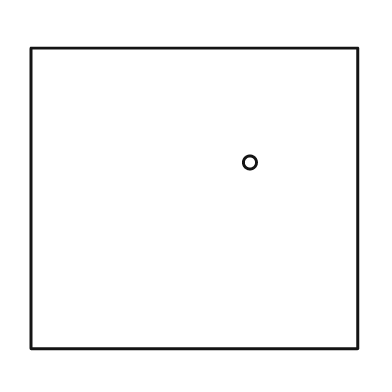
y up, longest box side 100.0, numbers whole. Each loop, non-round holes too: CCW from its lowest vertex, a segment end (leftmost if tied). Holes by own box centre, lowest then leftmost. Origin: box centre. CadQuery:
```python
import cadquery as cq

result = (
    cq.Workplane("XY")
    .moveTo(-50.0, -46.0)
    .lineTo(50.0, -46.0)
    .lineTo(50.0, 46.0)
    .lineTo(-50.0, 46.0)
    .close()
    .moveTo(17.0, 11.0)
    .circle(2.0)
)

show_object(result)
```